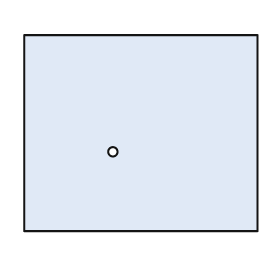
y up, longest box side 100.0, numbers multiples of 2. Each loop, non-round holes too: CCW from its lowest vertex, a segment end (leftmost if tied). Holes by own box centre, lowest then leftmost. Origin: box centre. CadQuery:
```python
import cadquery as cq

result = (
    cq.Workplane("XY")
    .moveTo(-50.0, -42.0)
    .lineTo(50.0, -42.0)
    .lineTo(50.0, 42.0)
    .lineTo(-50.0, 42.0)
    .close()
    .moveTo(-12.0, -8.0)
    .circle(2.0)
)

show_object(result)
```